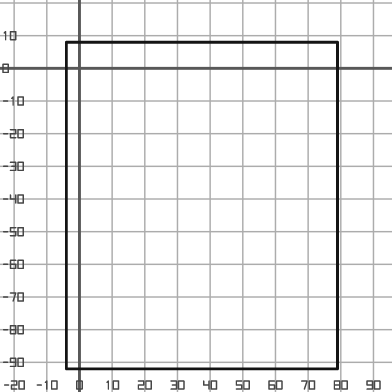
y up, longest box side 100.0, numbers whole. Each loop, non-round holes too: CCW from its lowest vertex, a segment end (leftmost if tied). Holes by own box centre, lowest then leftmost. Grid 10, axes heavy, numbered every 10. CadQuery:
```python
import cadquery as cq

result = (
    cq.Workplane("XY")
    .moveTo(-4.0, -92.0)
    .lineTo(79.0, -92.0)
    .lineTo(79.0, 8.0)
    .lineTo(-4.0, 8.0)
    .close()
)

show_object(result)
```